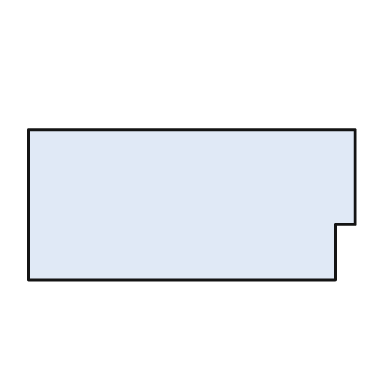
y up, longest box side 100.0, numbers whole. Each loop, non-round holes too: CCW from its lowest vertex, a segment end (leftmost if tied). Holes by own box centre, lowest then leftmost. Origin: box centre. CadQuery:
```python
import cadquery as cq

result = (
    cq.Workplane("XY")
    .moveTo(-50.0, -23.0)
    .lineTo(44.0, -23.0)
    .lineTo(44.0, -6.0)
    .lineTo(50.0, -6.0)
    .lineTo(50.0, 23.0)
    .lineTo(-50.0, 23.0)
    .close()
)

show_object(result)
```